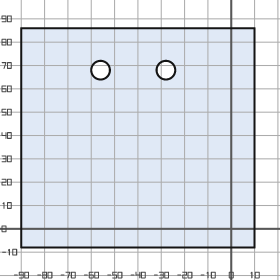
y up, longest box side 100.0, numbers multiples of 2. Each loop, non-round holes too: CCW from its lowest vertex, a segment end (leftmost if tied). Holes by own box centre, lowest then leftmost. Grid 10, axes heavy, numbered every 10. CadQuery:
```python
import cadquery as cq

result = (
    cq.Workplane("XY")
    .moveTo(-90.0, -8.0)
    .lineTo(10.0, -8.0)
    .lineTo(10.0, 86.0)
    .lineTo(-90.0, 86.0)
    .close()
    .moveTo(-56.0, 68.0)
    .circle(4.0)
    .moveTo(-28.0, 68.0)
    .circle(4.0)
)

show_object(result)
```